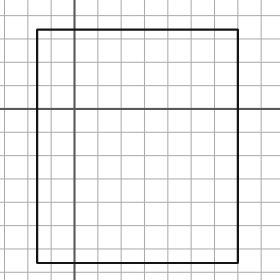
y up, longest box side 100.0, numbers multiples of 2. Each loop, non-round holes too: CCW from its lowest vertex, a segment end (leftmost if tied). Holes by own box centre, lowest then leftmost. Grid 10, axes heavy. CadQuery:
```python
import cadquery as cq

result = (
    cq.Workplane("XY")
    .moveTo(-16.0, -66.0)
    .lineTo(70.0, -66.0)
    .lineTo(70.0, 34.0)
    .lineTo(-16.0, 34.0)
    .close()
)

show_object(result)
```